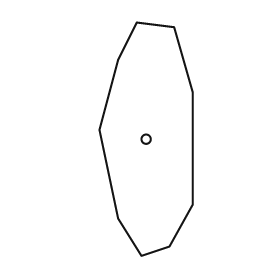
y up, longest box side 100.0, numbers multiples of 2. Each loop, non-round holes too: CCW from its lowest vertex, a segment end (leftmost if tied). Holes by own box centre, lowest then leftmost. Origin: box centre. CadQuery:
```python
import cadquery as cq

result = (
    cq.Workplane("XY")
    .moveTo(-2.0, -50.0)
    .lineTo(10.0, -46.0)
    .lineTo(20.0, -28.0)
    .lineTo(20.0, 20.0)
    .lineTo(12.0, 48.0)
    .lineTo(-4.0, 50.0)
    .lineTo(-12.0, 34.0)
    .lineTo(-20.0, 4.0)
    .lineTo(-12.0, -34.0)
    .close()
    .moveTo(0.0, 0.0)
    .circle(2.0)
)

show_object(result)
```